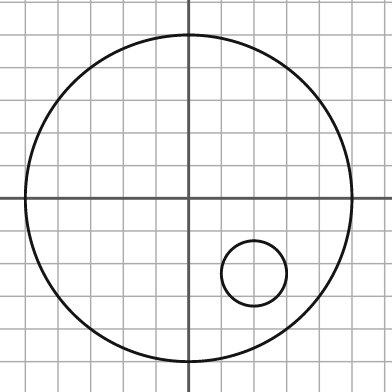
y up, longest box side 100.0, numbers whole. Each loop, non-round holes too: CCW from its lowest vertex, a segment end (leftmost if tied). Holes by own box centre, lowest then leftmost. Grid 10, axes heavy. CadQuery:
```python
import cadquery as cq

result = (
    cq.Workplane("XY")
    .moveTo(0.0, 0.0)
    .circle(50.0)
    .moveTo(20.0, -23.0)
    .circle(10.0)
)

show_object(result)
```